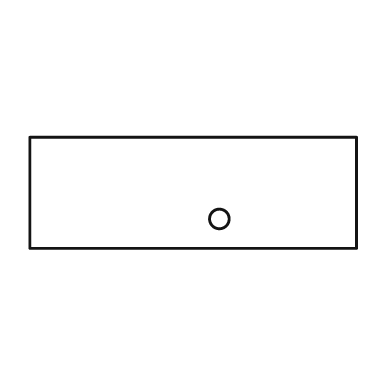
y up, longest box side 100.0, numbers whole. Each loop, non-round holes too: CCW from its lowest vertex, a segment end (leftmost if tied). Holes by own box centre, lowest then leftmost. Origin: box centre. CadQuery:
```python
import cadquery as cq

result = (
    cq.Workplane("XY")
    .moveTo(-50.0, -17.0)
    .lineTo(50.0, -17.0)
    .lineTo(50.0, 17.0)
    .lineTo(-50.0, 17.0)
    .close()
    .moveTo(8.0, -8.0)
    .circle(3.0)
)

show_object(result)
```